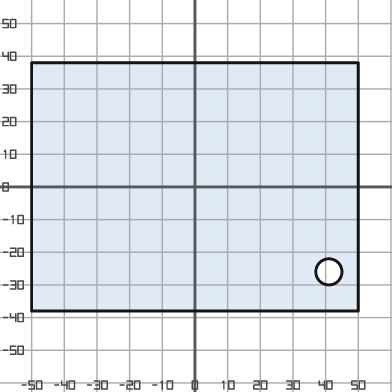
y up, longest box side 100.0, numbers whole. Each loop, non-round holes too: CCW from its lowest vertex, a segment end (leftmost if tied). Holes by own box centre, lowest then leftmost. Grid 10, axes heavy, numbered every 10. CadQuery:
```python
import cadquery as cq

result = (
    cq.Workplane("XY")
    .moveTo(-50.0, -38.0)
    .lineTo(50.0, -38.0)
    .lineTo(50.0, 38.0)
    .lineTo(-50.0, 38.0)
    .close()
    .moveTo(41.0, -26.0)
    .circle(4.0)
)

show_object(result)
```